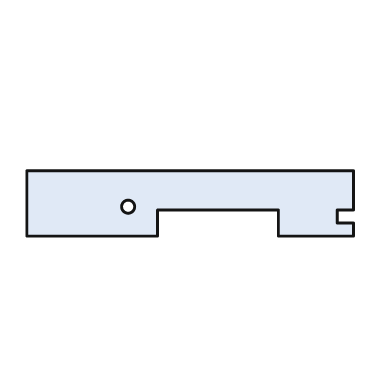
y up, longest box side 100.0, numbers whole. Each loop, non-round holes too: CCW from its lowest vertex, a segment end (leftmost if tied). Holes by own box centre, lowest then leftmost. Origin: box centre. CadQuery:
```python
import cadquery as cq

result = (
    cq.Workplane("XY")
    .moveTo(-50.0, -10.0)
    .lineTo(-10.0, -10.0)
    .lineTo(-10.0, -2.0)
    .lineTo(27.0, -2.0)
    .lineTo(27.0, -10.0)
    .lineTo(50.0, -10.0)
    .lineTo(50.0, -6.0)
    .lineTo(45.0, -6.0)
    .lineTo(45.0, -2.0)
    .lineTo(50.0, -2.0)
    .lineTo(50.0, 10.0)
    .lineTo(-50.0, 10.0)
    .close()
    .moveTo(-19.0, -1.0)
    .circle(2.0)
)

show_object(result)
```